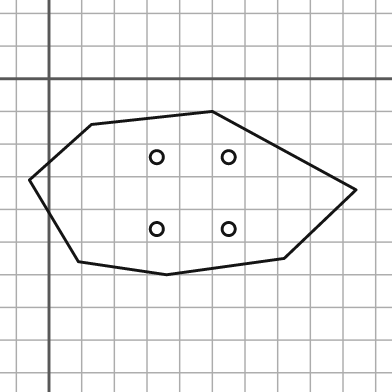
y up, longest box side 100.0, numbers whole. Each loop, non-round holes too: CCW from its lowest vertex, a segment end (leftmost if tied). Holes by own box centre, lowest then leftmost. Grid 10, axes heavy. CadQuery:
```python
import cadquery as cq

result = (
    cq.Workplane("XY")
    .moveTo(36.0, -60.0)
    .lineTo(72.0, -55.0)
    .lineTo(94.0, -34.0)
    .lineTo(50.0, -10.0)
    .lineTo(13.0, -14.0)
    .lineTo(-6.0, -31.0)
    .lineTo(9.0, -56.0)
    .close()
    .moveTo(33.0, -46.0)
    .circle(2.0)
    .moveTo(55.0, -46.0)
    .circle(2.0)
    .moveTo(33.0, -24.0)
    .circle(2.0)
    .moveTo(55.0, -24.0)
    .circle(2.0)
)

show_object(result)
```